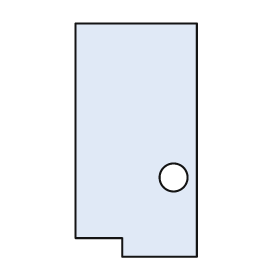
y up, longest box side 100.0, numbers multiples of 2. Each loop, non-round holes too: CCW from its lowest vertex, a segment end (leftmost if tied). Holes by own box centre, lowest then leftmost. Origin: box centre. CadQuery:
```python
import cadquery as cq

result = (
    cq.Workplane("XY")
    .moveTo(-6.0, -50.0)
    .lineTo(26.0, -50.0)
    .lineTo(26.0, 50.0)
    .lineTo(-26.0, 50.0)
    .lineTo(-26.0, -42.0)
    .lineTo(-6.0, -42.0)
    .close()
    .moveTo(16.0, -16.0)
    .circle(6.0)
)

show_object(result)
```